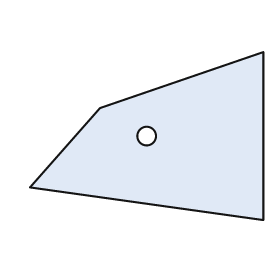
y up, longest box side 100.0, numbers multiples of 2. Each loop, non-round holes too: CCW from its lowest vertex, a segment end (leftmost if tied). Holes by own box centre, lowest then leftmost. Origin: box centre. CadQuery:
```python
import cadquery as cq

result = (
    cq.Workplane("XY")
    .moveTo(50.0, -36.0)
    .lineTo(50.0, 36.0)
    .lineTo(-20.0, 12.0)
    .lineTo(-50.0, -22.0)
    .close()
    .moveTo(0.0, 0.0)
    .circle(4.0)
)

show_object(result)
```